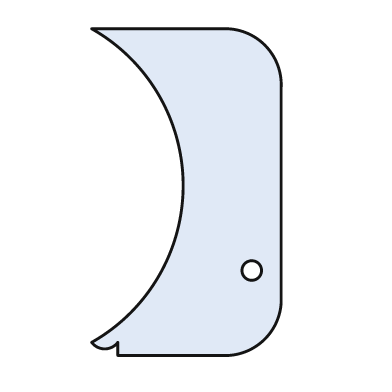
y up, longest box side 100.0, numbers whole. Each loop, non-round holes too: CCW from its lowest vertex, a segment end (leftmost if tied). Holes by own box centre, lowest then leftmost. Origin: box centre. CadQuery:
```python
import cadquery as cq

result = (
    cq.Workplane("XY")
    .moveTo(-21.0, -50.0)
    .lineTo(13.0, -50.0)
    .threePointArc((24.0, -45.0), (29.0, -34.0))
    .lineTo(29.0, 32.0)
    .threePointArc((24.0, 45.0), (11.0, 50.0))
    .lineTo(-29.0, 50.0)
    .threePointArc((-1.0, 2.0), (-29.0, -46.0))
    .threePointArc((-25.0, -48.0), (-21.0, -46.0))
    .close()
    .moveTo(20.0, -24.0)
    .circle(3.0)
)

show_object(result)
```